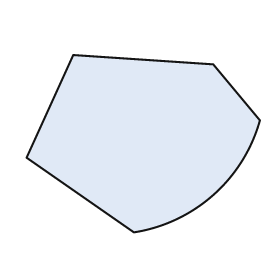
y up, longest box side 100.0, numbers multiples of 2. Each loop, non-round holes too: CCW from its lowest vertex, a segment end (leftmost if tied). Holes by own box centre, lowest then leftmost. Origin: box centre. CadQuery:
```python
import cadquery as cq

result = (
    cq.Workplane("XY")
    .moveTo(-4.0, -38.0)
    .threePointArc((30.0, -22.0), (50.0, 10.0))
    .lineTo(30.0, 34.0)
    .lineTo(-30.0, 38.0)
    .lineTo(-50.0, -6.0)
    .close()
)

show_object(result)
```